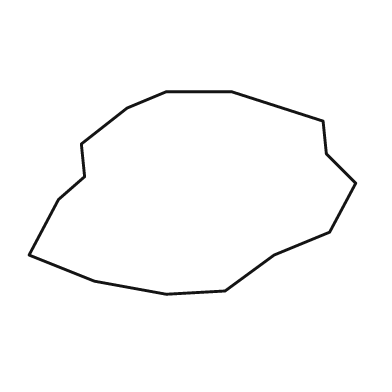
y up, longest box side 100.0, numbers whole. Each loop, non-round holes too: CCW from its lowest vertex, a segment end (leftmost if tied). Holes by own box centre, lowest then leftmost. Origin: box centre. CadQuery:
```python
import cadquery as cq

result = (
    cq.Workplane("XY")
    .moveTo(-8.0, -31.0)
    .lineTo(10.0, -30.0)
    .lineTo(25.0, -19.0)
    .lineTo(42.0, -12.0)
    .lineTo(50.0, 3.0)
    .lineTo(41.0, 12.0)
    .lineTo(40.0, 22.0)
    .lineTo(12.0, 31.0)
    .lineTo(-8.0, 31.0)
    .lineTo(-20.0, 26.0)
    .lineTo(-34.0, 15.0)
    .lineTo(-33.0, 5.0)
    .lineTo(-41.0, -2.0)
    .lineTo(-50.0, -19.0)
    .lineTo(-30.0, -27.0)
    .close()
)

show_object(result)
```